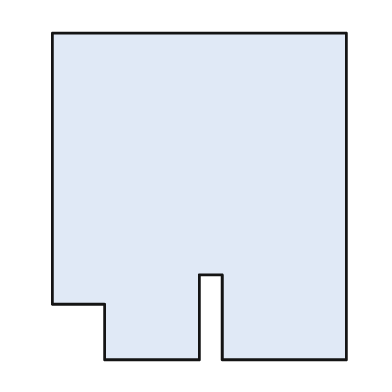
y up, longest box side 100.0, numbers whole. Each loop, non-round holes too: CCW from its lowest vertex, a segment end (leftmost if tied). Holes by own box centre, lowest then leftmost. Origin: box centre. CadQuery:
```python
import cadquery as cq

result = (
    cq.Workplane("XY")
    .moveTo(-29.0, -50.0)
    .lineTo(0.0, -50.0)
    .lineTo(0.0, -24.0)
    .lineTo(7.0, -24.0)
    .lineTo(7.0, -50.0)
    .lineTo(45.0, -50.0)
    .lineTo(45.0, 50.0)
    .lineTo(-45.0, 50.0)
    .lineTo(-45.0, -33.0)
    .lineTo(-29.0, -33.0)
    .close()
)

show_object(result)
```